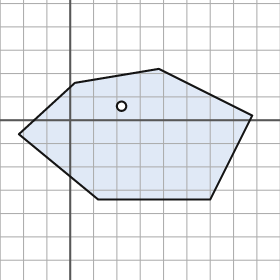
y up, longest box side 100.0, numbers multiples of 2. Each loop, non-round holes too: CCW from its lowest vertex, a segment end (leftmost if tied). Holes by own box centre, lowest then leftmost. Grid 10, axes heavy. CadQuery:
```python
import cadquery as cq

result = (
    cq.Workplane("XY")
    .moveTo(12.0, -34.0)
    .lineTo(60.0, -34.0)
    .lineTo(78.0, 2.0)
    .lineTo(38.0, 22.0)
    .lineTo(2.0, 16.0)
    .lineTo(-22.0, -6.0)
    .close()
    .moveTo(22.0, 6.0)
    .circle(2.0)
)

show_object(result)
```